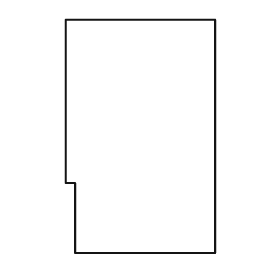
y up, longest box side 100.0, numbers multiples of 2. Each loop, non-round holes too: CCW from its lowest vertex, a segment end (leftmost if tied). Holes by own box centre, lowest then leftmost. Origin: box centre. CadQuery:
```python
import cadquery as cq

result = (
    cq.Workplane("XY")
    .moveTo(-28.0, -50.0)
    .lineTo(32.0, -50.0)
    .lineTo(32.0, 50.0)
    .lineTo(-32.0, 50.0)
    .lineTo(-32.0, -20.0)
    .lineTo(-28.0, -20.0)
    .close()
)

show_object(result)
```